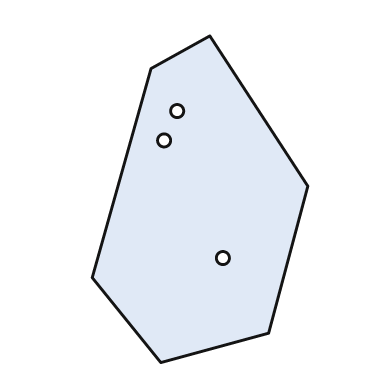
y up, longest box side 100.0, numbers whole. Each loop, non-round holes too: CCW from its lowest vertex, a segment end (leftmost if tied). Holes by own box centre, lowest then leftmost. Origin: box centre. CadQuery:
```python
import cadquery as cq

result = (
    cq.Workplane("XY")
    .moveTo(-12.0, -50.0)
    .lineTo(21.0, -41.0)
    .lineTo(33.0, 4.0)
    .lineTo(3.0, 50.0)
    .lineTo(-15.0, 40.0)
    .lineTo(-33.0, -24.0)
    .close()
    .moveTo(7.0, -18.0)
    .circle(2.0)
    .moveTo(-11.0, 18.0)
    .circle(2.0)
    .moveTo(-7.0, 27.0)
    .circle(2.0)
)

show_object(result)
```